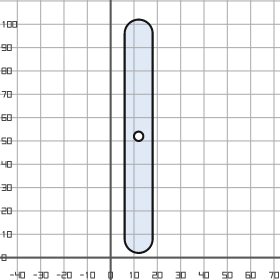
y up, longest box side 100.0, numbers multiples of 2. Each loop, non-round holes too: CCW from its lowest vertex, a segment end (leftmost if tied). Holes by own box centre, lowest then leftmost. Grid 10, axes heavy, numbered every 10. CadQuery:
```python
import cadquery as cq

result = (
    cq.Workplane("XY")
    .moveTo(6.0, 8.0)
    .threePointArc((12.0, 2.0), (18.0, 8.0))
    .lineTo(18.0, 96.0)
    .threePointArc((12.0, 102.0), (6.0, 96.0))
    .close()
    .moveTo(12.0, 52.0)
    .circle(2.0)
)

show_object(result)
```